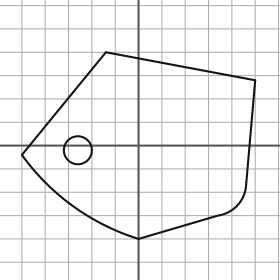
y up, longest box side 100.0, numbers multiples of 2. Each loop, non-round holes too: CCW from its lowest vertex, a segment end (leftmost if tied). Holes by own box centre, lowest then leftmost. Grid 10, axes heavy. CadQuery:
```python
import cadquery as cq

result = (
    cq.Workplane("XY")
    .moveTo(0.0, -40.0)
    .lineTo(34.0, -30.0)
    .threePointArc((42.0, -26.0), (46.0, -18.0))
    .lineTo(50.0, 28.0)
    .lineTo(-14.0, 40.0)
    .lineTo(-50.0, -4.0)
    .threePointArc((-28.0, -26.0), (0.0, -40.0))
    .close()
    .moveTo(-26.0, -2.0)
    .circle(6.0)
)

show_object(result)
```